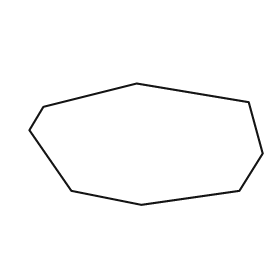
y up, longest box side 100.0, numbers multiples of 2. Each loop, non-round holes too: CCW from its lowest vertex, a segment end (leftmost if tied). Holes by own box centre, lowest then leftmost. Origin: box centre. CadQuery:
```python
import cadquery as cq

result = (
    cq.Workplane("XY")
    .moveTo(-2.0, -26.0)
    .lineTo(40.0, -20.0)
    .lineTo(50.0, -4.0)
    .lineTo(44.0, 18.0)
    .lineTo(-4.0, 26.0)
    .lineTo(-44.0, 16.0)
    .lineTo(-50.0, 6.0)
    .lineTo(-32.0, -20.0)
    .close()
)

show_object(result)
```